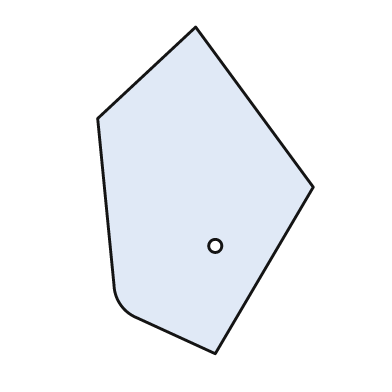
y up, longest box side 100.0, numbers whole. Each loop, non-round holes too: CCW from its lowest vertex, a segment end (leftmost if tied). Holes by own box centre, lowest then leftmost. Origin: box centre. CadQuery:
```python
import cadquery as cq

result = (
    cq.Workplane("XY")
    .moveTo(3.0, -50.0)
    .lineTo(33.0, 1.0)
    .lineTo(-3.0, 50.0)
    .lineTo(-33.0, 22.0)
    .lineTo(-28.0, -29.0)
    .threePointArc((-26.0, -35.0), (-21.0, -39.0))
    .close()
    .moveTo(3.0, -17.0)
    .circle(2.0)
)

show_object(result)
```